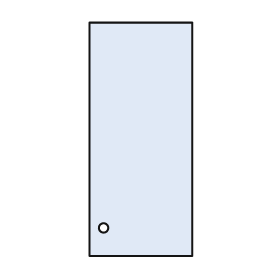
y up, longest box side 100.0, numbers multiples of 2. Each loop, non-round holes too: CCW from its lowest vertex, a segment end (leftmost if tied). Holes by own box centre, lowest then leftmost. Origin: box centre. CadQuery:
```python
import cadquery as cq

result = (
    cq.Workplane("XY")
    .moveTo(-22.0, -50.0)
    .lineTo(22.0, -50.0)
    .lineTo(22.0, 50.0)
    .lineTo(-22.0, 50.0)
    .close()
    .moveTo(-16.0, -38.0)
    .circle(2.0)
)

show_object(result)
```